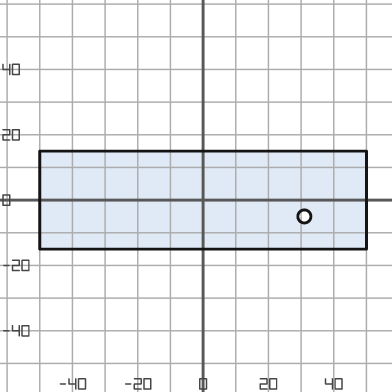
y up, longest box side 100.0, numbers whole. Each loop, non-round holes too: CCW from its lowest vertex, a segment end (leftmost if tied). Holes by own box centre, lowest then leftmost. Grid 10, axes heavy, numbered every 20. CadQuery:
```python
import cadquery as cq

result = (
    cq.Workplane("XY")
    .moveTo(-50.0, -15.0)
    .lineTo(50.0, -15.0)
    .lineTo(50.0, 15.0)
    .lineTo(-50.0, 15.0)
    .close()
    .moveTo(31.0, -5.0)
    .circle(2.0)
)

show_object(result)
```